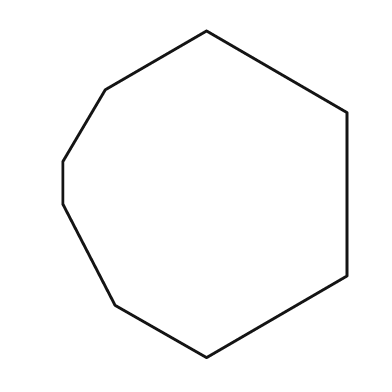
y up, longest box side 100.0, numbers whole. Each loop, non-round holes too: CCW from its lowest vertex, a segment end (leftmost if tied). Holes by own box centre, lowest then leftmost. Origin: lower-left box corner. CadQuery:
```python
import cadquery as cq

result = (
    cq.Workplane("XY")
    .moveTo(44.0, 0.0)
    .lineTo(87.0, 25.0)
    .lineTo(87.0, 75.0)
    .lineTo(44.0, 100.0)
    .lineTo(13.0, 82.0)
    .lineTo(0.0, 60.0)
    .lineTo(0.0, 47.0)
    .lineTo(16.0, 16.0)
    .close()
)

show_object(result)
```